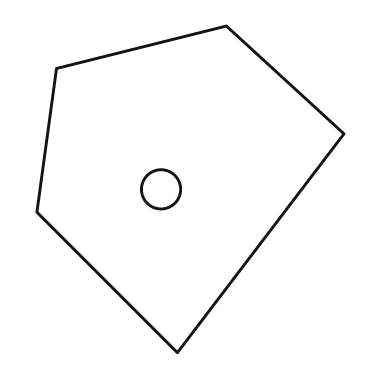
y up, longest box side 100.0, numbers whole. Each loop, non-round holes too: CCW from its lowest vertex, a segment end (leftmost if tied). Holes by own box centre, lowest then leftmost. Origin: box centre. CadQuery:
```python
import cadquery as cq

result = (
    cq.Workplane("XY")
    .moveTo(-4.0, -50.0)
    .lineTo(47.0, 17.0)
    .lineTo(11.0, 50.0)
    .lineTo(-41.0, 37.0)
    .lineTo(-47.0, -7.0)
    .close()
    .moveTo(-9.0, 0.0)
    .circle(6.0)
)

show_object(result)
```